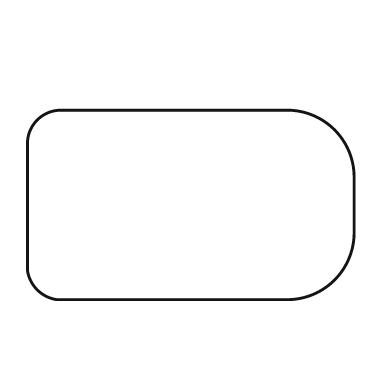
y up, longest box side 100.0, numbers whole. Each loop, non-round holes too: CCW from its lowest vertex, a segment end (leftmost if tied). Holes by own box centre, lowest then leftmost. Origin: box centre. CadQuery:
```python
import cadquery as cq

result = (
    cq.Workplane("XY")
    .moveTo(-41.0, -29.0)
    .lineTo(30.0, -29.0)
    .threePointArc((44.0, -23.0), (50.0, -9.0))
    .lineTo(50.0, 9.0)
    .threePointArc((44.0, 23.0), (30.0, 29.0))
    .lineTo(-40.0, 29.0)
    .threePointArc((-47.0, 26.0), (-50.0, 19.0))
    .lineTo(-50.0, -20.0)
    .threePointArc((-47.0, -26.0), (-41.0, -29.0))
    .close()
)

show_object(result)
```